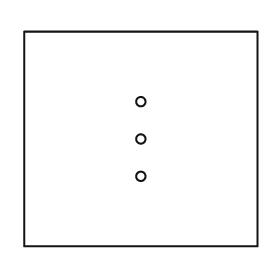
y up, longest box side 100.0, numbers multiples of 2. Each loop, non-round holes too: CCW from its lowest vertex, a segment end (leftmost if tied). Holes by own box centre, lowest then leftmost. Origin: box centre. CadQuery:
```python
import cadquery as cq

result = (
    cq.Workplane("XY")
    .moveTo(-50.0, -46.0)
    .lineTo(50.0, -46.0)
    .lineTo(50.0, 46.0)
    .lineTo(-50.0, 46.0)
    .close()
    .moveTo(0.0, -16.0)
    .circle(2.0)
    .moveTo(0.0, 0.0)
    .circle(2.0)
    .moveTo(0.0, 16.0)
    .circle(2.0)
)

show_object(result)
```